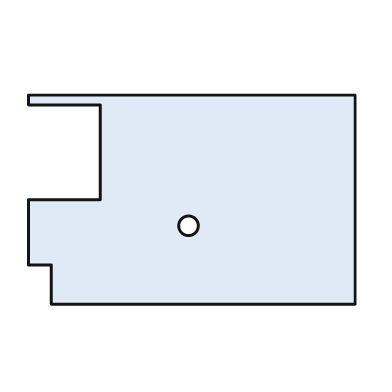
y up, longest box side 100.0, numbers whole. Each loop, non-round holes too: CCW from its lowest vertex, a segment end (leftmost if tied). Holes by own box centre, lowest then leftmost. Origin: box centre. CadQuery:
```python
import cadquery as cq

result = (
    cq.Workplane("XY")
    .moveTo(-43.0, -32.0)
    .lineTo(50.0, -32.0)
    .lineTo(50.0, 32.0)
    .lineTo(-50.0, 32.0)
    .lineTo(-50.0, 29.0)
    .lineTo(-28.0, 29.0)
    .lineTo(-28.0, 0.0)
    .lineTo(-50.0, 0.0)
    .lineTo(-50.0, -20.0)
    .lineTo(-43.0, -20.0)
    .close()
    .moveTo(-1.0, -8.0)
    .circle(3.0)
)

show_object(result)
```